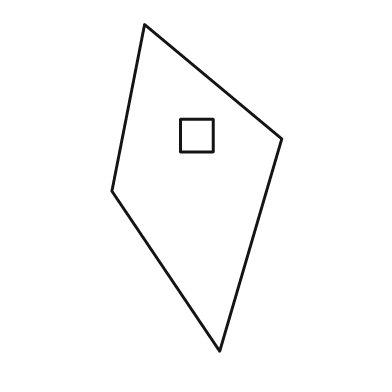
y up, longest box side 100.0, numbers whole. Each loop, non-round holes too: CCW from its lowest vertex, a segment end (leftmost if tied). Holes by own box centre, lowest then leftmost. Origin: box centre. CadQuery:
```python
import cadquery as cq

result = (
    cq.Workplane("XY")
    .moveTo(7.0, -50.0)
    .lineTo(26.0, 15.0)
    .lineTo(-16.0, 50.0)
    .lineTo(-26.0, -1.0)
    .close()
    .moveTo(-5.0, 11.0)
    .lineTo(5.0, 11.0)
    .lineTo(5.0, 21.0)
    .lineTo(-5.0, 21.0)
    .close()
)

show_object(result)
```